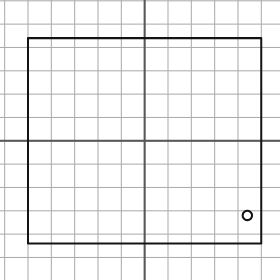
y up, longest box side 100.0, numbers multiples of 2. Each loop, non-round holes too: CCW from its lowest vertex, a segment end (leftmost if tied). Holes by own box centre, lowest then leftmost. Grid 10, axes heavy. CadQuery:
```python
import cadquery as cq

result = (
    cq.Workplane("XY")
    .moveTo(-50.0, -44.0)
    .lineTo(50.0, -44.0)
    .lineTo(50.0, 44.0)
    .lineTo(-50.0, 44.0)
    .close()
    .moveTo(44.0, -32.0)
    .circle(2.0)
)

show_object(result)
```